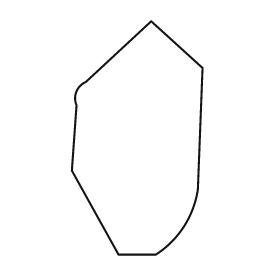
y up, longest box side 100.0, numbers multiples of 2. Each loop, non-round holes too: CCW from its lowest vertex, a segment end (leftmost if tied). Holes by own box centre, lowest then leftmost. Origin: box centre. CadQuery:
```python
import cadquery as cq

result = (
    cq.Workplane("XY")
    .moveTo(-8.0, -50.0)
    .lineTo(8.0, -50.0)
    .threePointArc((20.0, -38.0), (26.0, -22.0))
    .lineTo(28.0, 30.0)
    .lineTo(6.0, 50.0)
    .lineTo(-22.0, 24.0)
    .threePointArc((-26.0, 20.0), (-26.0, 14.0))
    .lineTo(-28.0, -14.0)
    .close()
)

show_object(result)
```